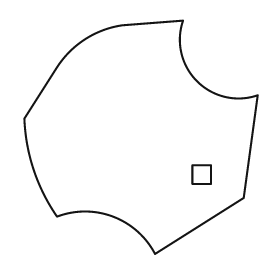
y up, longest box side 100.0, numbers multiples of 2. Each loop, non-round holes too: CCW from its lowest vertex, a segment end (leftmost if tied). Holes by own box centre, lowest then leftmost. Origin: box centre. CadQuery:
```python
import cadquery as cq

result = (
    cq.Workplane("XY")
    .moveTo(6.0, -50.0)
    .lineTo(44.0, -26.0)
    .lineTo(50.0, 18.0)
    .threePointArc((24.0, 24.0), (18.0, 50.0))
    .lineTo(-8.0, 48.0)
    .threePointArc((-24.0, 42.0), (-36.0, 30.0))
    .lineTo(-50.0, 8.0)
    .threePointArc((-46.0, -14.0), (-36.0, -34.0))
    .threePointArc((-12.0, -34.0), (6.0, -50.0))
    .close()
    .moveTo(22.0, -20.0)
    .lineTo(30.0, -20.0)
    .lineTo(30.0, -12.0)
    .lineTo(22.0, -12.0)
    .close()
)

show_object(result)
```